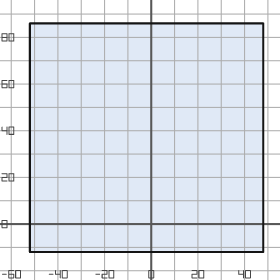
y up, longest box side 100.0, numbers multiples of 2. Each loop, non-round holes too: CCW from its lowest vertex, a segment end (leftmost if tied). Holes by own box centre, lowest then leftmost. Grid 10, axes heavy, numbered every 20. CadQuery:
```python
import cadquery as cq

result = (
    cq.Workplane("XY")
    .moveTo(-52.0, -12.0)
    .lineTo(48.0, -12.0)
    .lineTo(48.0, 86.0)
    .lineTo(-52.0, 86.0)
    .close()
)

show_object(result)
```